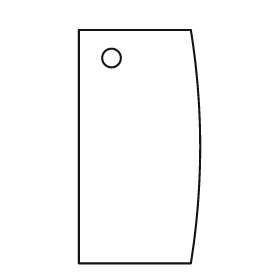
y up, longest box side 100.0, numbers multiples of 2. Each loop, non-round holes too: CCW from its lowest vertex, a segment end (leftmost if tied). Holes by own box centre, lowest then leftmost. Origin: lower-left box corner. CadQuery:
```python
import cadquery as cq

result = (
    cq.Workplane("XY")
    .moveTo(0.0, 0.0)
    .lineTo(48.0, 0.0)
    .threePointArc((52.0, 50.0), (48.0, 100.0))
    .lineTo(0.0, 100.0)
    .close()
    .moveTo(14.0, 88.0)
    .circle(4.0)
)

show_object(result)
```